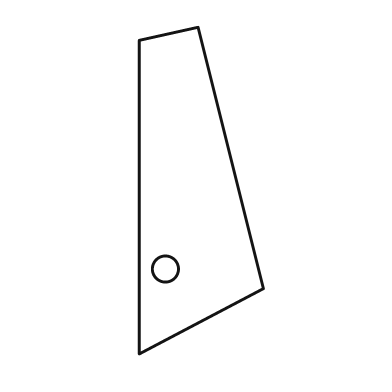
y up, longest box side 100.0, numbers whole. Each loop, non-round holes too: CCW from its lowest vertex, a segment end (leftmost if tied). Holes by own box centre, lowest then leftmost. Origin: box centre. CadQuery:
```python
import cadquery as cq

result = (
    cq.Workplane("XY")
    .moveTo(-19.0, -50.0)
    .lineTo(19.0, -30.0)
    .lineTo(-1.0, 50.0)
    .lineTo(-19.0, 46.0)
    .close()
    .moveTo(-11.0, -24.0)
    .circle(4.0)
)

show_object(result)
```